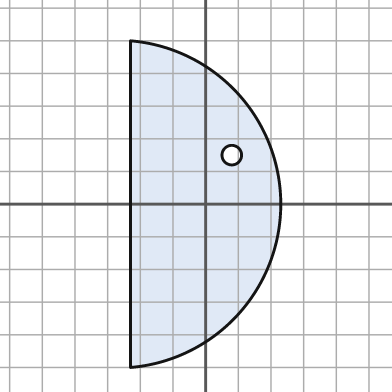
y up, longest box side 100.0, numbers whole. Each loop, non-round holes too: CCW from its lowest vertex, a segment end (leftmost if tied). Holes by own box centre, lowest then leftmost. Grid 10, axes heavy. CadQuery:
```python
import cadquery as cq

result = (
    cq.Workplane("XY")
    .moveTo(-23.0, -50.0)
    .threePointArc((23.0, 0.0), (-23.0, 50.0))
    .close()
    .moveTo(8.0, 15.0)
    .circle(3.0)
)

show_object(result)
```